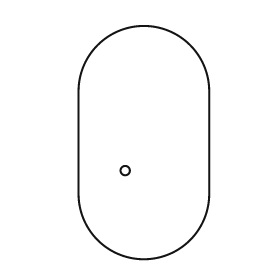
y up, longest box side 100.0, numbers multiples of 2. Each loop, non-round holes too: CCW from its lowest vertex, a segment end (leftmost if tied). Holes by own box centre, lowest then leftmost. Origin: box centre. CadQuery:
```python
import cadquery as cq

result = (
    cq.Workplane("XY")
    .moveTo(-28.0, -22.0)
    .threePointArc((0.0, -50.0), (28.0, -22.0))
    .lineTo(28.0, 22.0)
    .threePointArc((0.0, 50.0), (-28.0, 22.0))
    .close()
    .moveTo(-8.0, -12.0)
    .circle(2.0)
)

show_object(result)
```